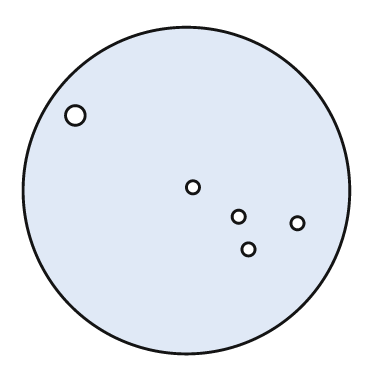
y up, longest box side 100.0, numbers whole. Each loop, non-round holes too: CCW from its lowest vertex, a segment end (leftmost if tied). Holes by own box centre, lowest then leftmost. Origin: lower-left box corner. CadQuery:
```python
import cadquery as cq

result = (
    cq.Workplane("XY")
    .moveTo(50.0, 50.0)
    .circle(50.0)
    .moveTo(69.0, 32.0)
    .circle(2.0)
    .moveTo(84.0, 40.0)
    .circle(2.0)
    .moveTo(66.0, 42.0)
    .circle(2.0)
    .moveTo(52.0, 51.0)
    .circle(2.0)
    .moveTo(16.0, 73.0)
    .circle(3.0)
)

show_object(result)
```